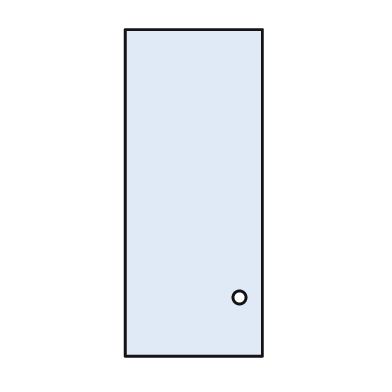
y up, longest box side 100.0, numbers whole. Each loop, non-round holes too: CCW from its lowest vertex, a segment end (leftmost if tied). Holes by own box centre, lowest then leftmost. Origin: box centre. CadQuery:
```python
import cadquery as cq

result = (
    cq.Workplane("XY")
    .moveTo(-21.0, -50.0)
    .lineTo(21.0, -50.0)
    .lineTo(21.0, 50.0)
    .lineTo(-21.0, 50.0)
    .close()
    .moveTo(14.0, -32.0)
    .circle(2.0)
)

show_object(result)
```